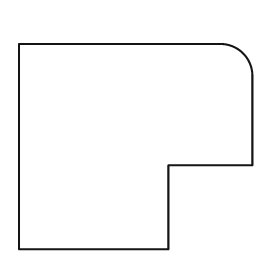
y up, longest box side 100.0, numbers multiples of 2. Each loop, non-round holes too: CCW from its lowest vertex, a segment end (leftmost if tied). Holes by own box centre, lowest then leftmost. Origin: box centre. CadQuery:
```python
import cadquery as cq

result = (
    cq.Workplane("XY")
    .moveTo(-50.0, -44.0)
    .lineTo(14.0, -44.0)
    .lineTo(14.0, -8.0)
    .lineTo(50.0, -8.0)
    .lineTo(50.0, 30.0)
    .threePointArc((46.0, 40.0), (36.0, 44.0))
    .lineTo(-50.0, 44.0)
    .close()
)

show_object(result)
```